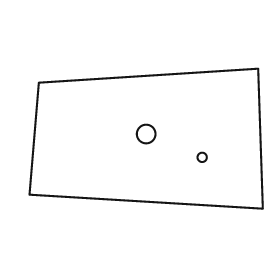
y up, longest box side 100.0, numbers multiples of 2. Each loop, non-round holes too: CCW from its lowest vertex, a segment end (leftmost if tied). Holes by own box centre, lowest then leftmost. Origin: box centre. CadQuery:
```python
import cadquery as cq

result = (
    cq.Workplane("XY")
    .moveTo(50.0, -30.0)
    .lineTo(48.0, 30.0)
    .lineTo(-46.0, 24.0)
    .lineTo(-50.0, -24.0)
    .close()
    .moveTo(24.0, -8.0)
    .circle(2.0)
    .moveTo(0.0, 2.0)
    .circle(4.0)
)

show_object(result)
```